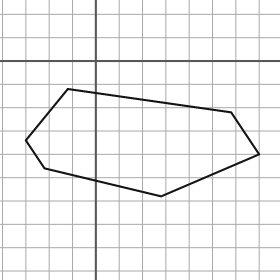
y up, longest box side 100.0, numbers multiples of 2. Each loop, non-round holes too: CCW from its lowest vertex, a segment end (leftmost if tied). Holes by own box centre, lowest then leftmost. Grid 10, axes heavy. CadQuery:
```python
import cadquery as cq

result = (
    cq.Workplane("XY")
    .moveTo(28.0, -58.0)
    .lineTo(70.0, -40.0)
    .lineTo(58.0, -22.0)
    .lineTo(-12.0, -12.0)
    .lineTo(-30.0, -34.0)
    .lineTo(-22.0, -46.0)
    .close()
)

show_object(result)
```